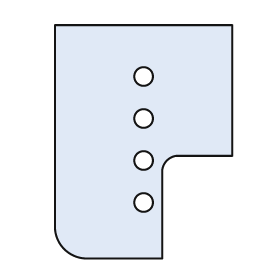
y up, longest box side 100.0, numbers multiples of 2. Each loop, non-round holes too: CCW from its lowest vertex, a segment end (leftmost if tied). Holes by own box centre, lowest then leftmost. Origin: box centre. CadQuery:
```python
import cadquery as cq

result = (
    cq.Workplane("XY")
    .moveTo(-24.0, -50.0)
    .lineTo(8.0, -50.0)
    .lineTo(8.0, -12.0)
    .threePointArc((10.0, -8.0), (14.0, -6.0))
    .lineTo(38.0, -6.0)
    .lineTo(38.0, 50.0)
    .lineTo(-38.0, 50.0)
    .lineTo(-38.0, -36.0)
    .threePointArc((-34.0, -46.0), (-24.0, -50.0))
    .close()
    .moveTo(0.0, -26.0)
    .circle(4.0)
    .moveTo(0.0, -8.0)
    .circle(4.0)
    .moveTo(0.0, 10.0)
    .circle(4.0)
    .moveTo(0.0, 28.0)
    .circle(4.0)
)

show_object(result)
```